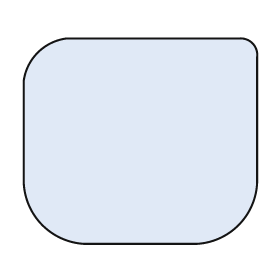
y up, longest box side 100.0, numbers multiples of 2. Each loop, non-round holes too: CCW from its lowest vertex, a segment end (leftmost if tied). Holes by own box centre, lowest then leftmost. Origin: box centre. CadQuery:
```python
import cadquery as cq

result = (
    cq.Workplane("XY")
    .moveTo(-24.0, -44.0)
    .lineTo(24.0, -44.0)
    .threePointArc((42.0, -36.0), (50.0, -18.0))
    .lineTo(50.0, 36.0)
    .threePointArc((48.0, 42.0), (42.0, 44.0))
    .lineTo(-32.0, 44.0)
    .threePointArc((-44.0, 38.0), (-50.0, 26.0))
    .lineTo(-50.0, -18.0)
    .threePointArc((-42.0, -36.0), (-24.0, -44.0))
    .close()
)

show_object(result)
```